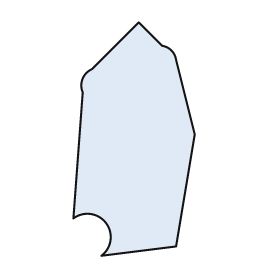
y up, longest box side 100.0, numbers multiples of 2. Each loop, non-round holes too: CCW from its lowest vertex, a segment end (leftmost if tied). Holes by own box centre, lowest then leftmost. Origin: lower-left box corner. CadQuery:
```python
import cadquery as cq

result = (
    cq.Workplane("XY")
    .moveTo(12.0, 0.0)
    .lineTo(44.0, 4.0)
    .lineTo(52.0, 52.0)
    .lineTo(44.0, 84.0)
    .threePointArc((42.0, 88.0), (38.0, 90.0))
    .lineTo(28.0, 100.0)
    .lineTo(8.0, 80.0)
    .threePointArc((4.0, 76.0), (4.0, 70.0))
    .lineTo(0.0, 16.0)
    .threePointArc((14.0, 14.0), (12.0, 0.0))
    .close()
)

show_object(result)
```